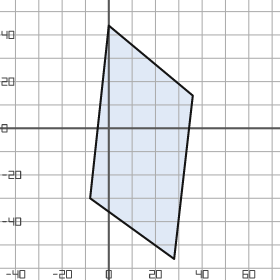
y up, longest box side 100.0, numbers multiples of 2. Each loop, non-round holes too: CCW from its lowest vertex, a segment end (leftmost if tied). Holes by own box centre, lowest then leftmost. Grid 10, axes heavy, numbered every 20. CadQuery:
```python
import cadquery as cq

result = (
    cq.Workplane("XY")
    .moveTo(28.0, -56.0)
    .lineTo(36.0, 14.0)
    .lineTo(0.0, 44.0)
    .lineTo(-8.0, -30.0)
    .close()
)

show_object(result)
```